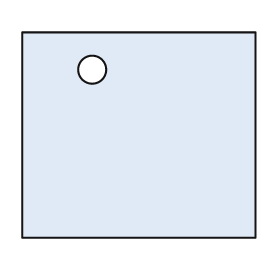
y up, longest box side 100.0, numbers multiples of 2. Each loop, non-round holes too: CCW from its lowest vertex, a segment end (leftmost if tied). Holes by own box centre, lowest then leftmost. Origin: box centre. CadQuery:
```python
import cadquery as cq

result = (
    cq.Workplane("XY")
    .moveTo(-50.0, -44.0)
    .lineTo(50.0, -44.0)
    .lineTo(50.0, 44.0)
    .lineTo(-50.0, 44.0)
    .close()
    .moveTo(-20.0, 28.0)
    .circle(6.0)
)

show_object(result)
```